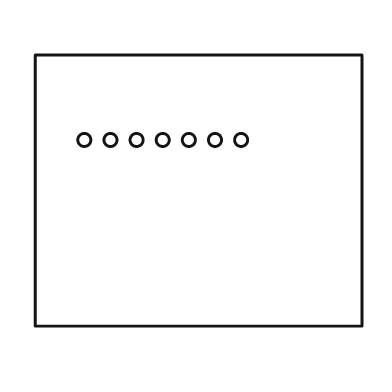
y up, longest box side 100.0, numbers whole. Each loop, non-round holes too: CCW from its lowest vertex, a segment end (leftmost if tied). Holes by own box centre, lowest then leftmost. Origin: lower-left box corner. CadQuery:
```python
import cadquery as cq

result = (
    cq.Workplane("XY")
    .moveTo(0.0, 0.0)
    .lineTo(100.0, 0.0)
    .lineTo(100.0, 83.0)
    .lineTo(0.0, 83.0)
    .close()
    .moveTo(15.0, 57.0)
    .circle(2.0)
    .moveTo(23.0, 57.0)
    .circle(2.0)
    .moveTo(31.0, 57.0)
    .circle(2.0)
    .moveTo(39.0, 57.0)
    .circle(2.0)
    .moveTo(47.0, 57.0)
    .circle(2.0)
    .moveTo(55.0, 57.0)
    .circle(2.0)
    .moveTo(63.0, 57.0)
    .circle(2.0)
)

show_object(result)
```